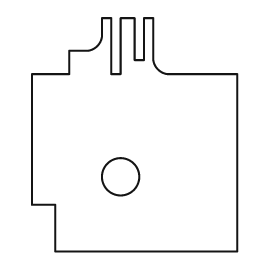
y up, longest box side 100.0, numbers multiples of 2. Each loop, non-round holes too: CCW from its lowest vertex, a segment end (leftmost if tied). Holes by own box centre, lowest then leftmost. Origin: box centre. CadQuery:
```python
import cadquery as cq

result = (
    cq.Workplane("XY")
    .moveTo(-34.0, -50.0)
    .lineTo(44.0, -50.0)
    .lineTo(44.0, 26.0)
    .lineTo(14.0, 26.0)
    .threePointArc((10.0, 28.0), (8.0, 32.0))
    .lineTo(8.0, 50.0)
    .lineTo(4.0, 50.0)
    .lineTo(4.0, 32.0)
    .lineTo(0.0, 32.0)
    .lineTo(0.0, 50.0)
    .lineTo(-6.0, 50.0)
    .lineTo(-6.0, 26.0)
    .lineTo(-10.0, 26.0)
    .lineTo(-10.0, 50.0)
    .lineTo(-14.0, 50.0)
    .lineTo(-14.0, 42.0)
    .threePointArc((-16.0, 38.0), (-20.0, 36.0))
    .lineTo(-28.0, 36.0)
    .lineTo(-28.0, 26.0)
    .lineTo(-44.0, 26.0)
    .lineTo(-44.0, -30.0)
    .lineTo(-34.0, -30.0)
    .close()
    .moveTo(-6.0, -18.0)
    .circle(8.0)
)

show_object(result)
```